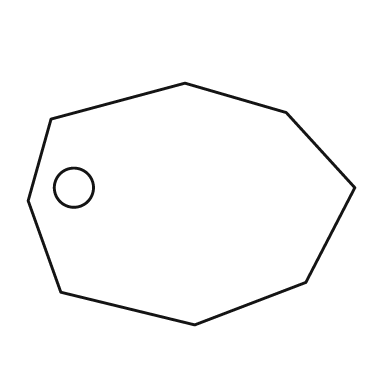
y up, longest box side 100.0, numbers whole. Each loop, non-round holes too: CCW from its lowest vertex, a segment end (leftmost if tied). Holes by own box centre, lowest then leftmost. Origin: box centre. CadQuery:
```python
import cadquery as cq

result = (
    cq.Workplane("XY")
    .moveTo(1.0, -37.0)
    .lineTo(35.0, -24.0)
    .lineTo(50.0, 5.0)
    .lineTo(29.0, 28.0)
    .lineTo(-2.0, 37.0)
    .lineTo(-43.0, 26.0)
    .lineTo(-50.0, 1.0)
    .lineTo(-40.0, -27.0)
    .close()
    .moveTo(-36.0, 5.0)
    .circle(6.0)
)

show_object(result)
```